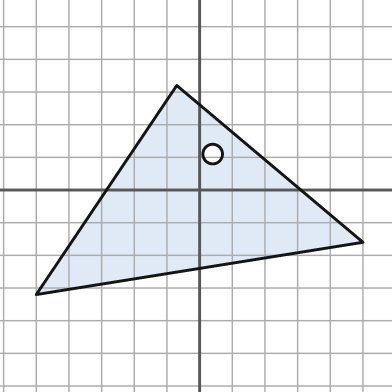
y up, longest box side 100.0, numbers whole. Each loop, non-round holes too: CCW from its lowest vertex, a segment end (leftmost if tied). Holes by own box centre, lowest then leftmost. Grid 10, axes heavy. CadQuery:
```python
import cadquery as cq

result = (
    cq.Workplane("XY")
    .moveTo(-50.0, -32.0)
    .lineTo(50.0, -16.0)
    .lineTo(-7.0, 32.0)
    .close()
    .moveTo(4.0, 11.0)
    .circle(3.0)
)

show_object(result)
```